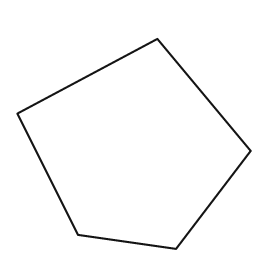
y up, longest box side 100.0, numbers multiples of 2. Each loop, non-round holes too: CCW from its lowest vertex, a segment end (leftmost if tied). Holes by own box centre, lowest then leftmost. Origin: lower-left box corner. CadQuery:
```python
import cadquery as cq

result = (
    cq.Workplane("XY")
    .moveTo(68.0, 0.0)
    .lineTo(100.0, 42.0)
    .lineTo(60.0, 90.0)
    .lineTo(0.0, 58.0)
    .lineTo(26.0, 6.0)
    .close()
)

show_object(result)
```